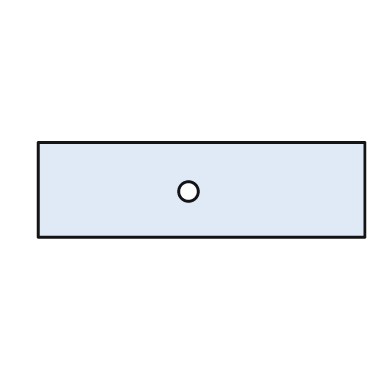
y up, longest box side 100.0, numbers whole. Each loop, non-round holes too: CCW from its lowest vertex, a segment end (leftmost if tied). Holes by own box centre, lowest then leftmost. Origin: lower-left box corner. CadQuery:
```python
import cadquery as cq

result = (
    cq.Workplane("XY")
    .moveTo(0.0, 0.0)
    .lineTo(100.0, 0.0)
    .lineTo(100.0, 29.0)
    .lineTo(0.0, 29.0)
    .close()
    .moveTo(46.0, 14.0)
    .circle(3.0)
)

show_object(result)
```